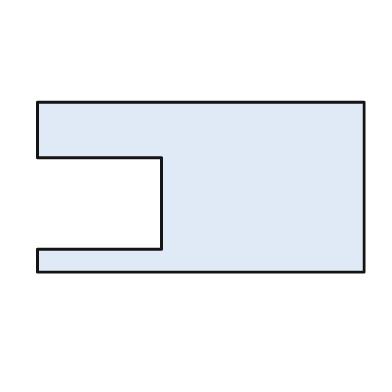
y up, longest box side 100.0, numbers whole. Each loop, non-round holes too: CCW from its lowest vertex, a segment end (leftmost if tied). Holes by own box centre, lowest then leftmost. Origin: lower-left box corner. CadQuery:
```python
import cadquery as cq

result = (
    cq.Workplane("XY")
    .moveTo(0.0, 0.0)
    .lineTo(100.0, 0.0)
    .lineTo(100.0, 52.0)
    .lineTo(0.0, 52.0)
    .lineTo(0.0, 35.0)
    .lineTo(38.0, 35.0)
    .lineTo(38.0, 7.0)
    .lineTo(0.0, 7.0)
    .close()
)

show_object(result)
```